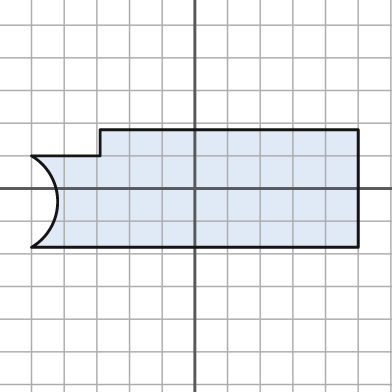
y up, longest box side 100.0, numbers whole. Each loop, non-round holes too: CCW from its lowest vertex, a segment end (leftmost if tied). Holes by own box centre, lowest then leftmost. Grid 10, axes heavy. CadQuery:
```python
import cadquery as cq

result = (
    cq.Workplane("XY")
    .moveTo(-50.0, -18.0)
    .lineTo(50.0, -18.0)
    .lineTo(50.0, 18.0)
    .lineTo(-29.0, 18.0)
    .lineTo(-29.0, 10.0)
    .lineTo(-50.0, 10.0)
    .threePointArc((-42.0, -4.0), (-50.0, -18.0))
    .close()
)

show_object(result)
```